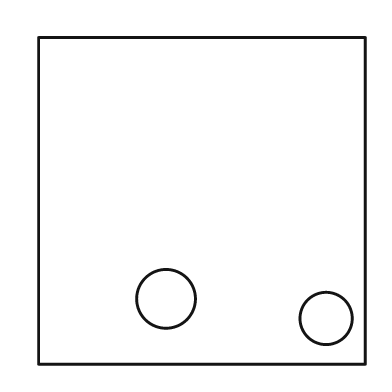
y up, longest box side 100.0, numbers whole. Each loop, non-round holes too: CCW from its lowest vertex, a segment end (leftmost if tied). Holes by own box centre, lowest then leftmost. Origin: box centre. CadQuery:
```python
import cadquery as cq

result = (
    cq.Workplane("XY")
    .moveTo(-50.0, -50.0)
    .lineTo(50.0, -50.0)
    .lineTo(50.0, 50.0)
    .lineTo(-50.0, 50.0)
    .close()
    .moveTo(38.0, -36.0)
    .circle(8.0)
    .moveTo(-11.0, -30.0)
    .circle(9.0)
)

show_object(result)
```